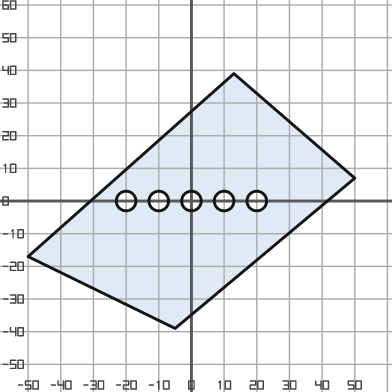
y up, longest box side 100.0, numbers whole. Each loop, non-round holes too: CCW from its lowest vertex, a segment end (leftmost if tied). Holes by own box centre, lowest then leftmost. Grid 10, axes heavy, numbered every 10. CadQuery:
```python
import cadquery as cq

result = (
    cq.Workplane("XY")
    .moveTo(-5.0, -39.0)
    .lineTo(50.0, 7.0)
    .lineTo(13.0, 39.0)
    .lineTo(-50.0, -17.0)
    .close()
    .moveTo(-20.0, 0.0)
    .circle(3.0)
    .moveTo(-10.0, 0.0)
    .circle(3.0)
    .moveTo(0.0, 0.0)
    .circle(3.0)
    .moveTo(10.0, 0.0)
    .circle(3.0)
    .moveTo(20.0, 0.0)
    .circle(3.0)
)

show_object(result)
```